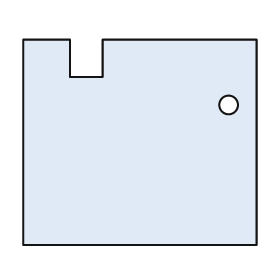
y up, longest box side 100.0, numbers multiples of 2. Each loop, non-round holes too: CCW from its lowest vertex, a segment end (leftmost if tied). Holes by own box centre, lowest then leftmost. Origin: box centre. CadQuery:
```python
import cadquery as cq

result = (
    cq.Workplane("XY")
    .moveTo(-50.0, -44.0)
    .lineTo(50.0, -44.0)
    .lineTo(50.0, 44.0)
    .lineTo(-16.0, 44.0)
    .lineTo(-16.0, 28.0)
    .lineTo(-30.0, 28.0)
    .lineTo(-30.0, 44.0)
    .lineTo(-50.0, 44.0)
    .close()
    .moveTo(38.0, 16.0)
    .circle(4.0)
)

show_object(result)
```